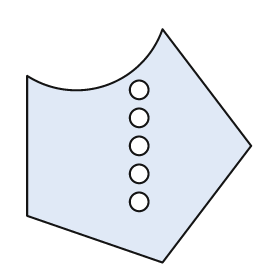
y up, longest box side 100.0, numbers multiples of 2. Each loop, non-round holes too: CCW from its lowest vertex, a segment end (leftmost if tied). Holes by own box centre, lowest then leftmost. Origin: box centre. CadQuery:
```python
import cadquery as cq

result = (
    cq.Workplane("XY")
    .moveTo(10.0, -50.0)
    .lineTo(48.0, 0.0)
    .lineTo(10.0, 50.0)
    .threePointArc((-14.0, 26.0), (-48.0, 30.0))
    .lineTo(-48.0, -30.0)
    .close()
    .moveTo(0.0, -24.0)
    .circle(4.0)
    .moveTo(0.0, -12.0)
    .circle(4.0)
    .moveTo(0.0, 0.0)
    .circle(4.0)
    .moveTo(0.0, 12.0)
    .circle(4.0)
    .moveTo(0.0, 24.0)
    .circle(4.0)
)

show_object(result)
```